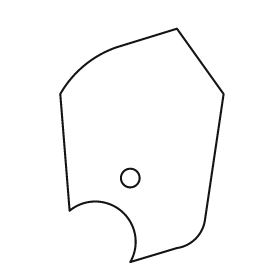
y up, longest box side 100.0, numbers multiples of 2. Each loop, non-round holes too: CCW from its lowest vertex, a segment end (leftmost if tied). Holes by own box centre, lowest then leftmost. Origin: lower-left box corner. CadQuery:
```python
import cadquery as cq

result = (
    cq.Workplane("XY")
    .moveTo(30.0, 0.0)
    .lineTo(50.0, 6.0)
    .threePointArc((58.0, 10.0), (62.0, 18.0))
    .lineTo(70.0, 72.0)
    .lineTo(50.0, 100.0)
    .lineTo(24.0, 92.0)
    .threePointArc((10.0, 84.0), (0.0, 72.0))
    .lineTo(4.0, 22.0)
    .threePointArc((26.0, 22.0), (30.0, 0.0))
    .close()
    .moveTo(30.0, 36.0)
    .circle(4.0)
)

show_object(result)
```